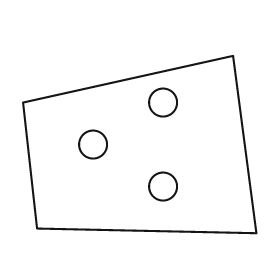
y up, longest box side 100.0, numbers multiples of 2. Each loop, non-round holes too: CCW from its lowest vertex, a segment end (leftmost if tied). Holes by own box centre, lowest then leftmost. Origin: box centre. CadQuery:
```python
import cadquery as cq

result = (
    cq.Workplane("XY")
    .moveTo(50.0, -38.0)
    .lineTo(40.0, 38.0)
    .lineTo(-50.0, 18.0)
    .lineTo(-44.0, -36.0)
    .close()
    .moveTo(10.0, -18.0)
    .circle(6.0)
    .moveTo(-20.0, 0.0)
    .circle(6.0)
    .moveTo(10.0, 18.0)
    .circle(6.0)
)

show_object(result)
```